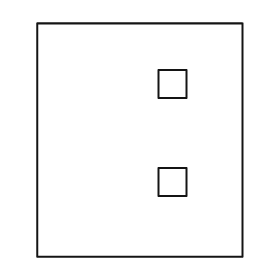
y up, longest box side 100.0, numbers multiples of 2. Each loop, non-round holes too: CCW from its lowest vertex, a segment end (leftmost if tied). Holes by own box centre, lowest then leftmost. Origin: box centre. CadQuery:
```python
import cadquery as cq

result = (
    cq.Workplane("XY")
    .moveTo(-44.0, -50.0)
    .lineTo(44.0, -50.0)
    .lineTo(44.0, 50.0)
    .lineTo(-44.0, 50.0)
    .close()
    .moveTo(8.0, -24.0)
    .lineTo(20.0, -24.0)
    .lineTo(20.0, -12.0)
    .lineTo(8.0, -12.0)
    .close()
    .moveTo(8.0, 18.0)
    .lineTo(20.0, 18.0)
    .lineTo(20.0, 30.0)
    .lineTo(8.0, 30.0)
    .close()
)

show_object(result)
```